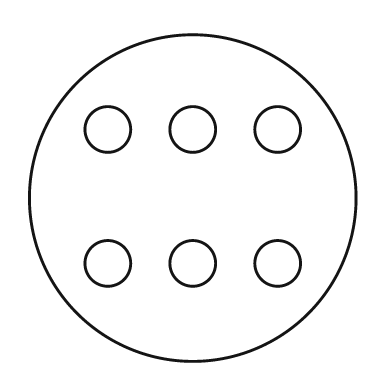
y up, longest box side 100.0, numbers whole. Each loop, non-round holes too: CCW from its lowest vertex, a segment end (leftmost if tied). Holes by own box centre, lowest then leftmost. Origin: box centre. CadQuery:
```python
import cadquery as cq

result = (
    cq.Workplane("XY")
    .moveTo(0.0, 0.0)
    .circle(50.0)
    .moveTo(-26.0, -20.0)
    .circle(7.0)
    .moveTo(0.0, -20.0)
    .circle(7.0)
    .moveTo(26.0, -20.0)
    .circle(7.0)
    .moveTo(-26.0, 21.0)
    .circle(7.0)
    .moveTo(0.0, 21.0)
    .circle(7.0)
    .moveTo(26.0, 21.0)
    .circle(7.0)
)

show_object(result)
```